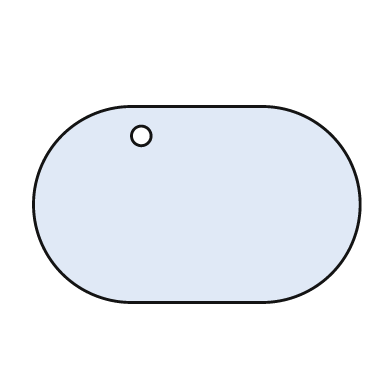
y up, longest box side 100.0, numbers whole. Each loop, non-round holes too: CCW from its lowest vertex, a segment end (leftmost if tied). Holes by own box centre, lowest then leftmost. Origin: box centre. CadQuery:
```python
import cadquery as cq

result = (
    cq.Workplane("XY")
    .moveTo(-20.0, -30.0)
    .lineTo(20.0, -30.0)
    .threePointArc((50.0, 0.0), (20.0, 30.0))
    .lineTo(-20.0, 30.0)
    .threePointArc((-50.0, 0.0), (-20.0, -30.0))
    .close()
    .moveTo(-17.0, 21.0)
    .circle(3.0)
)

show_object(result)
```